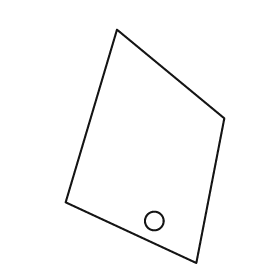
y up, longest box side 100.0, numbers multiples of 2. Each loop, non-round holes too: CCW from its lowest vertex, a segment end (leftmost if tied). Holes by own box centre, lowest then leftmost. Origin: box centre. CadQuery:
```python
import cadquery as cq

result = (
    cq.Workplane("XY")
    .moveTo(22.0, -50.0)
    .lineTo(34.0, 12.0)
    .lineTo(-12.0, 50.0)
    .lineTo(-34.0, -24.0)
    .close()
    .moveTo(4.0, -32.0)
    .circle(4.0)
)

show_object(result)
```